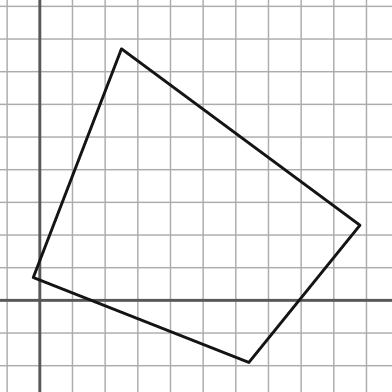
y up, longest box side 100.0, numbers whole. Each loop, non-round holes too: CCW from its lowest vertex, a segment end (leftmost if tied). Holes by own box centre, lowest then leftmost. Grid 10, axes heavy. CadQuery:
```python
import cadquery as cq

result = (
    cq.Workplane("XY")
    .moveTo(64.0, -19.0)
    .lineTo(98.0, 23.0)
    .lineTo(25.0, 77.0)
    .lineTo(-2.0, 7.0)
    .close()
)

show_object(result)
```